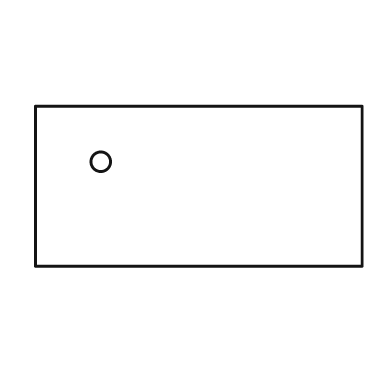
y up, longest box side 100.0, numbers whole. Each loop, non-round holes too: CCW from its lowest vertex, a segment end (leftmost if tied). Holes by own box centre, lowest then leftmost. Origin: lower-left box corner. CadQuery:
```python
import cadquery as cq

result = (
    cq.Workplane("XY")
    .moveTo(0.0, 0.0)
    .lineTo(100.0, 0.0)
    .lineTo(100.0, 49.0)
    .lineTo(0.0, 49.0)
    .close()
    .moveTo(20.0, 32.0)
    .circle(3.0)
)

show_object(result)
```